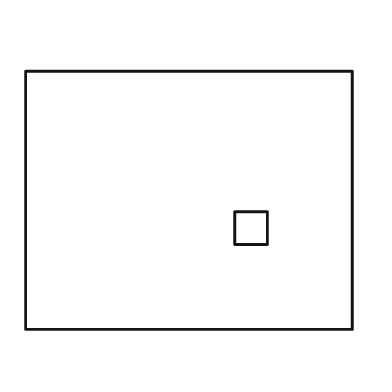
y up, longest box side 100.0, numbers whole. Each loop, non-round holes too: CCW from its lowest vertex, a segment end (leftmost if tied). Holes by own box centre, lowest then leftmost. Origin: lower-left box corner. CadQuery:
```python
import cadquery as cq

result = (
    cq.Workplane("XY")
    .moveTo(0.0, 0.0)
    .lineTo(100.0, 0.0)
    .lineTo(100.0, 79.0)
    .lineTo(0.0, 79.0)
    .close()
    .moveTo(64.0, 26.0)
    .lineTo(74.0, 26.0)
    .lineTo(74.0, 36.0)
    .lineTo(64.0, 36.0)
    .close()
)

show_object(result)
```